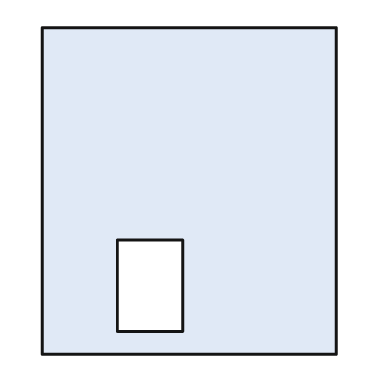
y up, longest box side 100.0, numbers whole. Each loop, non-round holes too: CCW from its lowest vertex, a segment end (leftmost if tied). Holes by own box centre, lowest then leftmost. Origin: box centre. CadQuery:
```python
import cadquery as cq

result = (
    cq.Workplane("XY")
    .moveTo(-45.0, -50.0)
    .lineTo(45.0, -50.0)
    .lineTo(45.0, 50.0)
    .lineTo(-45.0, 50.0)
    .close()
    .moveTo(-22.0, -43.0)
    .lineTo(-2.0, -43.0)
    .lineTo(-2.0, -15.0)
    .lineTo(-22.0, -15.0)
    .close()
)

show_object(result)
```